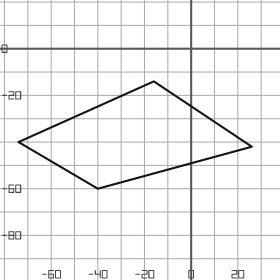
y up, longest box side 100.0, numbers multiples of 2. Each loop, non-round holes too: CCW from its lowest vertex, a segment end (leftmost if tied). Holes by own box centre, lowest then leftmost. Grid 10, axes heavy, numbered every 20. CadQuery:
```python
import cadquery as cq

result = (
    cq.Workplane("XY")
    .moveTo(-40.0, -60.0)
    .lineTo(26.0, -42.0)
    .lineTo(-16.0, -14.0)
    .lineTo(-74.0, -40.0)
    .close()
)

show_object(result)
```